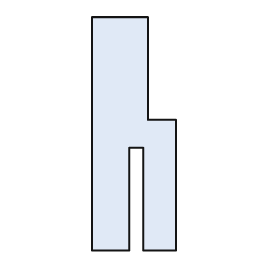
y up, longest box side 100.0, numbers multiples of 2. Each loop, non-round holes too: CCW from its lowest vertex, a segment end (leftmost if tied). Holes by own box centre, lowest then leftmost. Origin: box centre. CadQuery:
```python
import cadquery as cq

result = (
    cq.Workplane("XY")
    .moveTo(-18.0, -50.0)
    .lineTo(-2.0, -50.0)
    .lineTo(-2.0, -6.0)
    .lineTo(4.0, -6.0)
    .lineTo(4.0, -50.0)
    .lineTo(18.0, -50.0)
    .lineTo(18.0, 6.0)
    .lineTo(6.0, 6.0)
    .lineTo(6.0, 50.0)
    .lineTo(-18.0, 50.0)
    .close()
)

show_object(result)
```